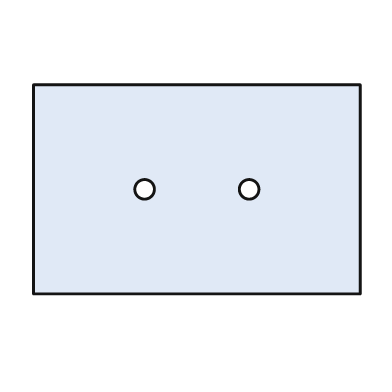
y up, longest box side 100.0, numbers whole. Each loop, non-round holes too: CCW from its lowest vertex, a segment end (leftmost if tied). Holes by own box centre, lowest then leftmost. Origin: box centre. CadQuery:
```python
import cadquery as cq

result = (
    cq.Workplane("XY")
    .moveTo(-50.0, -32.0)
    .lineTo(50.0, -32.0)
    .lineTo(50.0, 32.0)
    .lineTo(-50.0, 32.0)
    .close()
    .moveTo(-16.0, 0.0)
    .circle(3.0)
    .moveTo(16.0, 0.0)
    .circle(3.0)
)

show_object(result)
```